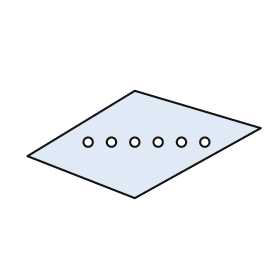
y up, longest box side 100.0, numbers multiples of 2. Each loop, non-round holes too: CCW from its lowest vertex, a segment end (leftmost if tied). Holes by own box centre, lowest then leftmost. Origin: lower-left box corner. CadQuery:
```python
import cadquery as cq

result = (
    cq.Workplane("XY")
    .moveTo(46.0, 0.0)
    .lineTo(100.0, 30.0)
    .lineTo(46.0, 46.0)
    .lineTo(0.0, 18.0)
    .close()
    .moveTo(26.0, 24.0)
    .circle(2.0)
    .moveTo(36.0, 24.0)
    .circle(2.0)
    .moveTo(46.0, 24.0)
    .circle(2.0)
    .moveTo(56.0, 24.0)
    .circle(2.0)
    .moveTo(66.0, 24.0)
    .circle(2.0)
    .moveTo(76.0, 24.0)
    .circle(2.0)
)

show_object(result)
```